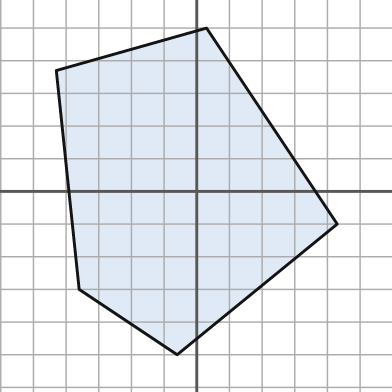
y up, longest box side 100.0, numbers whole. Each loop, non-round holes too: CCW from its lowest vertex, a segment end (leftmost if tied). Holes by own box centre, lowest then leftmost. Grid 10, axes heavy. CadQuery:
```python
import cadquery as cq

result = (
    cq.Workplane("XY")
    .moveTo(-6.0, -50.0)
    .lineTo(43.0, -10.0)
    .lineTo(3.0, 50.0)
    .lineTo(-43.0, 37.0)
    .lineTo(-36.0, -30.0)
    .close()
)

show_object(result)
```